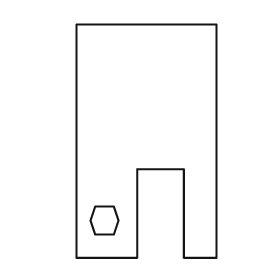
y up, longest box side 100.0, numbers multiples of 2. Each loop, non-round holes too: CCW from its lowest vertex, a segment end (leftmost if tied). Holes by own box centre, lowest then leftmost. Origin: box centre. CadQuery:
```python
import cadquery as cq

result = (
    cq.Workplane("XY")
    .moveTo(-30.0, -50.0)
    .lineTo(-4.0, -50.0)
    .lineTo(-4.0, -12.0)
    .lineTo(16.0, -12.0)
    .lineTo(16.0, -50.0)
    .lineTo(30.0, -50.0)
    .lineTo(30.0, 50.0)
    .lineTo(-30.0, 50.0)
    .close()
    .moveTo(-22.0, -40.0)
    .lineTo(-14.0, -40.0)
    .lineTo(-12.0, -34.0)
    .lineTo(-14.0, -28.0)
    .lineTo(-22.0, -28.0)
    .lineTo(-24.0, -34.0)
    .close()
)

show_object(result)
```